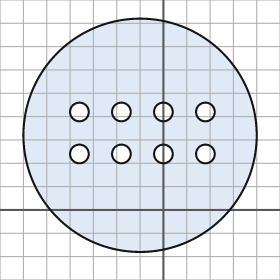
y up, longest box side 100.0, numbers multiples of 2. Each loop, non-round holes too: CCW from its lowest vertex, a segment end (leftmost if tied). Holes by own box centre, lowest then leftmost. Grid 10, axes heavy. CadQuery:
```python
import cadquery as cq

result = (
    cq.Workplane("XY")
    .moveTo(-10.0, 32.0)
    .circle(50.0)
    .moveTo(-36.0, 24.0)
    .circle(4.0)
    .moveTo(-18.0, 24.0)
    .circle(4.0)
    .moveTo(0.0, 24.0)
    .circle(4.0)
    .moveTo(18.0, 24.0)
    .circle(4.0)
    .moveTo(-36.0, 42.0)
    .circle(4.0)
    .moveTo(-18.0, 42.0)
    .circle(4.0)
    .moveTo(0.0, 42.0)
    .circle(4.0)
    .moveTo(18.0, 42.0)
    .circle(4.0)
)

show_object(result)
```